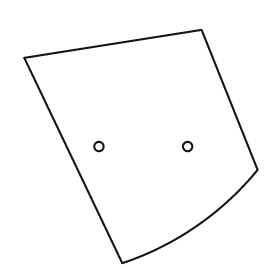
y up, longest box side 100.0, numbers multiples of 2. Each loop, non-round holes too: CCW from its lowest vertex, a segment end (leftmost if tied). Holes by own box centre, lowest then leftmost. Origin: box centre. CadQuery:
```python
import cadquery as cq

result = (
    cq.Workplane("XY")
    .moveTo(-8.0, -50.0)
    .threePointArc((24.0, -34.0), (50.0, -10.0))
    .lineTo(26.0, 50.0)
    .lineTo(-50.0, 38.0)
    .close()
    .moveTo(-18.0, 0.0)
    .circle(2.0)
    .moveTo(20.0, 0.0)
    .circle(2.0)
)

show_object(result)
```